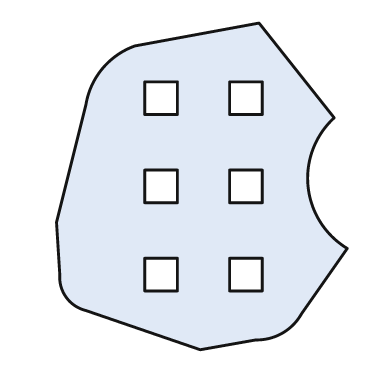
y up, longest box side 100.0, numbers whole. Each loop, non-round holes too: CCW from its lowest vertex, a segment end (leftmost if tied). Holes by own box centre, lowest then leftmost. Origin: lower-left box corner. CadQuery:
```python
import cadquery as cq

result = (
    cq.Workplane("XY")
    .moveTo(44.0, 0.0)
    .lineTo(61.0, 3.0)
    .threePointArc((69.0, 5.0), (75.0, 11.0))
    .lineTo(89.0, 31.0)
    .threePointArc((77.0, 50.0), (85.0, 71.0))
    .lineTo(62.0, 100.0)
    .lineTo(24.0, 93.0)
    .threePointArc((14.0, 86.0), (9.0, 75.0))
    .lineTo(0.0, 39.0)
    .lineTo(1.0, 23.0)
    .threePointArc((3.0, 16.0), (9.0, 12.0))
    .close()
    .moveTo(27.0, 18.0)
    .lineTo(37.0, 18.0)
    .lineTo(37.0, 28.0)
    .lineTo(27.0, 28.0)
    .close()
    .moveTo(53.0, 18.0)
    .lineTo(63.0, 18.0)
    .lineTo(63.0, 28.0)
    .lineTo(53.0, 28.0)
    .close()
    .moveTo(27.0, 45.0)
    .lineTo(37.0, 45.0)
    .lineTo(37.0, 55.0)
    .lineTo(27.0, 55.0)
    .close()
    .moveTo(53.0, 45.0)
    .lineTo(63.0, 45.0)
    .lineTo(63.0, 55.0)
    .lineTo(53.0, 55.0)
    .close()
    .moveTo(27.0, 72.0)
    .lineTo(37.0, 72.0)
    .lineTo(37.0, 82.0)
    .lineTo(27.0, 82.0)
    .close()
    .moveTo(53.0, 72.0)
    .lineTo(63.0, 72.0)
    .lineTo(63.0, 82.0)
    .lineTo(53.0, 82.0)
    .close()
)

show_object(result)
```